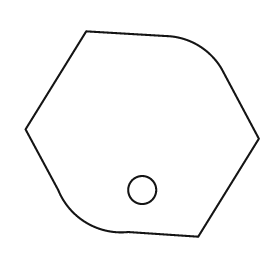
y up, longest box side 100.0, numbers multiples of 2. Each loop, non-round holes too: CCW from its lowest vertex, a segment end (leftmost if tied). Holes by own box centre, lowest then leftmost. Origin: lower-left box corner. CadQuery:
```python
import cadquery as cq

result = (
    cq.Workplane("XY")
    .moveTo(74.0, 0.0)
    .lineTo(100.0, 42.0)
    .lineTo(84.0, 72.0)
    .threePointArc((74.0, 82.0), (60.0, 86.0))
    .lineTo(26.0, 88.0)
    .lineTo(0.0, 46.0)
    .lineTo(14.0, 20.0)
    .threePointArc((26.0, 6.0), (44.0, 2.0))
    .close()
    .moveTo(50.0, 20.0)
    .circle(6.0)
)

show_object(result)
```